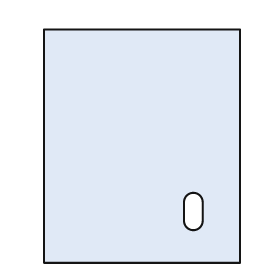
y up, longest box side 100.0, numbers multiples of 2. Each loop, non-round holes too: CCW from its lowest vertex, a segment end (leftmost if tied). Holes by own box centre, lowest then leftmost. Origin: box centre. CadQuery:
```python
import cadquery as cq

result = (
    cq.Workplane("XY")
    .moveTo(-42.0, -50.0)
    .lineTo(42.0, -50.0)
    .lineTo(42.0, 50.0)
    .lineTo(-42.0, 50.0)
    .close()
    .moveTo(18.0, -32.0)
    .threePointArc((22.0, -36.0), (26.0, -32.0))
    .lineTo(26.0, -24.0)
    .threePointArc((22.0, -20.0), (18.0, -24.0))
    .close()
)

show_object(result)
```